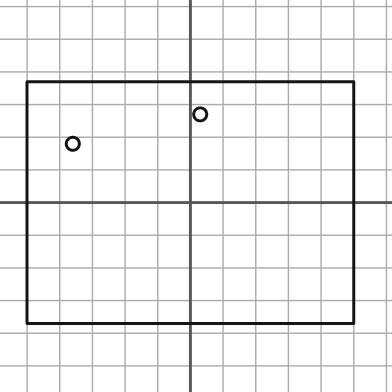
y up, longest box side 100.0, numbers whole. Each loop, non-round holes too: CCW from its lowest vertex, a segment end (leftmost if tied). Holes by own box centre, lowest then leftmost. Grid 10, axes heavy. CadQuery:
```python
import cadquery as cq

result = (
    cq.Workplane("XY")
    .moveTo(-50.0, -37.0)
    .lineTo(50.0, -37.0)
    .lineTo(50.0, 37.0)
    .lineTo(-50.0, 37.0)
    .close()
    .moveTo(-36.0, 18.0)
    .circle(2.0)
    .moveTo(3.0, 27.0)
    .circle(2.0)
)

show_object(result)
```